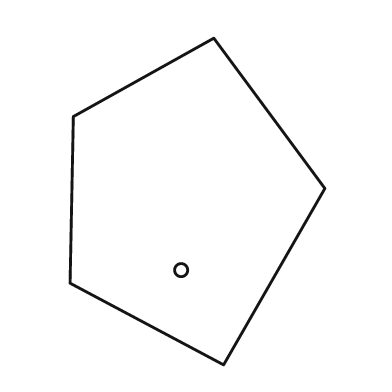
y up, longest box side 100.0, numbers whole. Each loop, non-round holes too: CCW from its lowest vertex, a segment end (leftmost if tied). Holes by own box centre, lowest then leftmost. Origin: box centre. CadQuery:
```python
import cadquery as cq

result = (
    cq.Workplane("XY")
    .moveTo(8.0, -50.0)
    .lineTo(39.0, 4.0)
    .lineTo(5.0, 50.0)
    .lineTo(-38.0, 26.0)
    .lineTo(-39.0, -25.0)
    .close()
    .moveTo(-5.0, -21.0)
    .circle(2.0)
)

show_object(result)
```